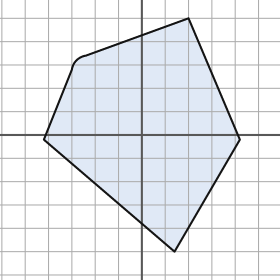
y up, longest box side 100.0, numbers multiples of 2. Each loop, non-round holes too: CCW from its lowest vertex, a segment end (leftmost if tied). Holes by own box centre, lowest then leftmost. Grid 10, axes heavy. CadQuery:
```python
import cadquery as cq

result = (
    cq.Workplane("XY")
    .moveTo(14.0, -50.0)
    .lineTo(42.0, -2.0)
    .lineTo(20.0, 50.0)
    .lineTo(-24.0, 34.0)
    .threePointArc((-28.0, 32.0), (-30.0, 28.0))
    .lineTo(-42.0, -2.0)
    .close()
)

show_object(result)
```